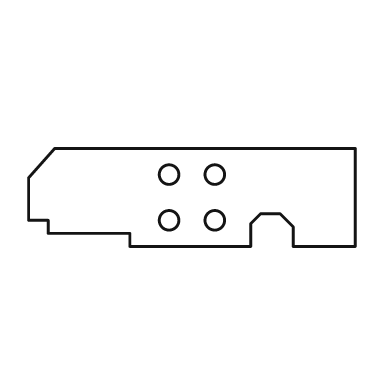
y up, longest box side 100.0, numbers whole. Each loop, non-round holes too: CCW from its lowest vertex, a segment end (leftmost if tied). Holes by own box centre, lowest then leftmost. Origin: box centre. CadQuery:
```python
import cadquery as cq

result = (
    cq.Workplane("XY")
    .moveTo(-19.0, -15.0)
    .lineTo(18.0, -15.0)
    .lineTo(18.0, -8.0)
    .lineTo(21.0, -5.0)
    .lineTo(27.0, -5.0)
    .lineTo(31.0, -9.0)
    .lineTo(31.0, -15.0)
    .lineTo(50.0, -15.0)
    .lineTo(50.0, 15.0)
    .lineTo(-42.0, 15.0)
    .lineTo(-50.0, 6.0)
    .lineTo(-50.0, -7.0)
    .lineTo(-44.0, -7.0)
    .lineTo(-44.0, -11.0)
    .lineTo(-19.0, -11.0)
    .close()
    .moveTo(-7.0, -7.0)
    .circle(3.0)
    .moveTo(7.0, -7.0)
    .circle(3.0)
    .moveTo(-7.0, 7.0)
    .circle(3.0)
    .moveTo(7.0, 7.0)
    .circle(3.0)
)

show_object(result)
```